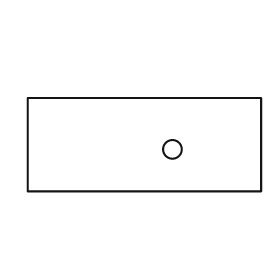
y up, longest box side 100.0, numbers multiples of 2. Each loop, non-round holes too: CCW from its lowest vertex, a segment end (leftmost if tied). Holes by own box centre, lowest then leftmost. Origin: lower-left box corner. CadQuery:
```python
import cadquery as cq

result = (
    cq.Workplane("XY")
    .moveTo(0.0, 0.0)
    .lineTo(100.0, 0.0)
    .lineTo(100.0, 40.0)
    .lineTo(0.0, 40.0)
    .close()
    .moveTo(62.0, 18.0)
    .circle(4.0)
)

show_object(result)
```